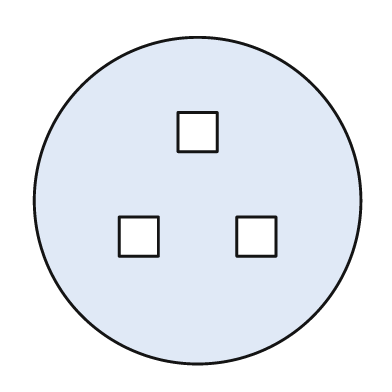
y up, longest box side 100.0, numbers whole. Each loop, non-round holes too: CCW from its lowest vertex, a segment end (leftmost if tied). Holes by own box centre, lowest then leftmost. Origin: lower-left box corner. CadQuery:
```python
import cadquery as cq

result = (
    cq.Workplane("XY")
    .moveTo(50.0, 50.0)
    .circle(50.0)
    .moveTo(26.0, 33.0)
    .lineTo(38.0, 33.0)
    .lineTo(38.0, 45.0)
    .lineTo(26.0, 45.0)
    .close()
    .moveTo(62.0, 33.0)
    .lineTo(74.0, 33.0)
    .lineTo(74.0, 45.0)
    .lineTo(62.0, 45.0)
    .close()
    .moveTo(44.0, 65.0)
    .lineTo(56.0, 65.0)
    .lineTo(56.0, 77.0)
    .lineTo(44.0, 77.0)
    .close()
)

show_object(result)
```